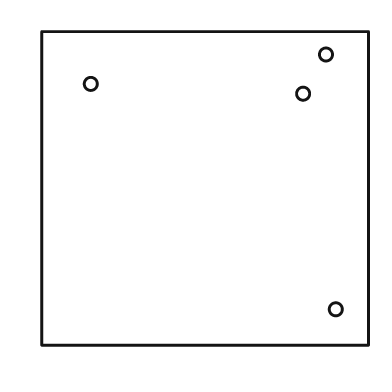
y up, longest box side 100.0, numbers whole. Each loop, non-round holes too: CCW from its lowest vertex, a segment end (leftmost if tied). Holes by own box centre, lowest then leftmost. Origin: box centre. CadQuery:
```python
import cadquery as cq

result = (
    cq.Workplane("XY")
    .moveTo(-50.0, -48.0)
    .lineTo(50.0, -48.0)
    .lineTo(50.0, 48.0)
    .lineTo(-50.0, 48.0)
    .close()
    .moveTo(40.0, -37.0)
    .circle(2.0)
    .moveTo(30.0, 29.0)
    .circle(2.0)
    .moveTo(-35.0, 32.0)
    .circle(2.0)
    .moveTo(37.0, 41.0)
    .circle(2.0)
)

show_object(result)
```